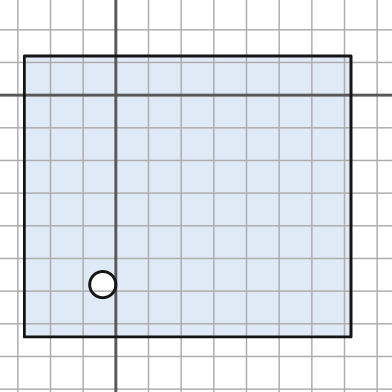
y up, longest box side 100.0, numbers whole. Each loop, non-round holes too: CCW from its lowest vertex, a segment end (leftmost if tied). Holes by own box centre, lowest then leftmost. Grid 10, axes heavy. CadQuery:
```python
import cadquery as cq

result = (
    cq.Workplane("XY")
    .moveTo(-28.0, -74.0)
    .lineTo(72.0, -74.0)
    .lineTo(72.0, 12.0)
    .lineTo(-28.0, 12.0)
    .close()
    .moveTo(-4.0, -58.0)
    .circle(4.0)
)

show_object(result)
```